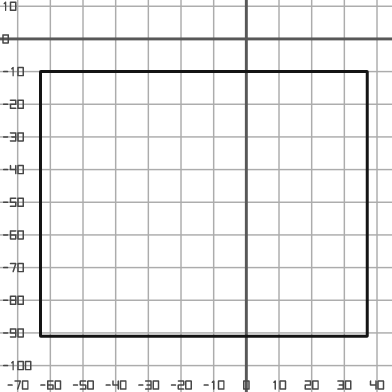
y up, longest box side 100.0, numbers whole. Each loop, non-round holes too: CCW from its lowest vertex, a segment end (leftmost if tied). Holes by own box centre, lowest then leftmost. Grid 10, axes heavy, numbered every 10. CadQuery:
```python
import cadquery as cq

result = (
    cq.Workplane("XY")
    .moveTo(-63.0, -91.0)
    .lineTo(37.0, -91.0)
    .lineTo(37.0, -10.0)
    .lineTo(-63.0, -10.0)
    .close()
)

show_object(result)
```